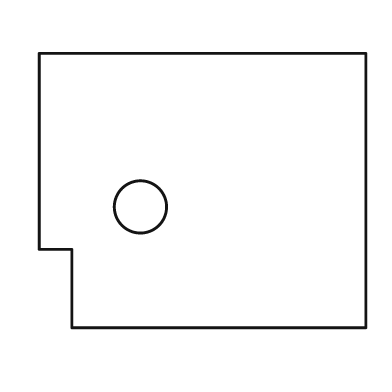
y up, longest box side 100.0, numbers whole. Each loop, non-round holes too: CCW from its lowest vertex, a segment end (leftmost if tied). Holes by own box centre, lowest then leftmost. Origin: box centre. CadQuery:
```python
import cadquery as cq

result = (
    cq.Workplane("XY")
    .moveTo(-40.0, -42.0)
    .lineTo(50.0, -42.0)
    .lineTo(50.0, 42.0)
    .lineTo(-50.0, 42.0)
    .lineTo(-50.0, -18.0)
    .lineTo(-40.0, -18.0)
    .close()
    .moveTo(-19.0, -5.0)
    .circle(8.0)
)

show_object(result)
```